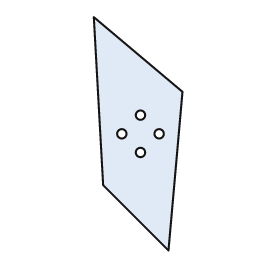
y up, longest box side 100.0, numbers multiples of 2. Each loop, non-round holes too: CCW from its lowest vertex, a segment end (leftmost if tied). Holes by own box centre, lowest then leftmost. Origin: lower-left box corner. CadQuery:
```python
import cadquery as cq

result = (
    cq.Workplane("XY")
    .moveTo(32.0, 0.0)
    .lineTo(38.0, 68.0)
    .lineTo(0.0, 100.0)
    .lineTo(4.0, 28.0)
    .close()
    .moveTo(20.0, 42.0)
    .circle(2.0)
    .moveTo(12.0, 50.0)
    .circle(2.0)
    .moveTo(28.0, 50.0)
    .circle(2.0)
    .moveTo(20.0, 58.0)
    .circle(2.0)
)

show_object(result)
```